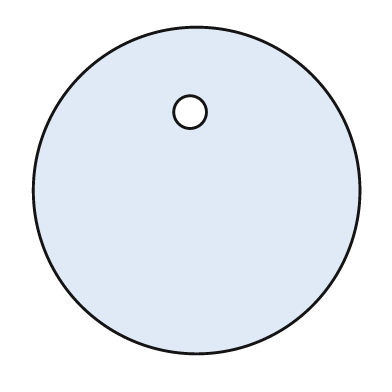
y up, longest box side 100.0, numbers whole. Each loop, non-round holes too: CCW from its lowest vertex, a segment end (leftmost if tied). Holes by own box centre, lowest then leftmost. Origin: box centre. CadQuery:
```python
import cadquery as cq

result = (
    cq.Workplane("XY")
    .moveTo(0.0, 0.0)
    .circle(50.0)
    .moveTo(-2.0, 24.0)
    .circle(5.0)
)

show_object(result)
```